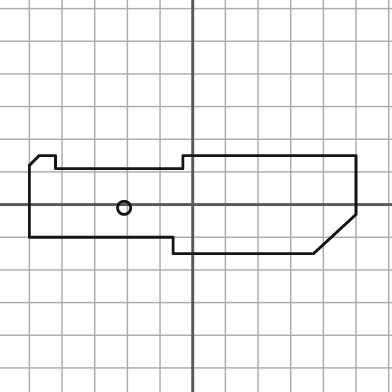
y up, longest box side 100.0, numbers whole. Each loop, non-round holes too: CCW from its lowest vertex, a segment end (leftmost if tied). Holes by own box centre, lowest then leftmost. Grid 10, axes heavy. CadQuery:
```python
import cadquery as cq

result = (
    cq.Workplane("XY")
    .moveTo(-6.0, -15.0)
    .lineTo(37.0, -15.0)
    .lineTo(50.0, -3.0)
    .lineTo(50.0, 15.0)
    .lineTo(-3.0, 15.0)
    .lineTo(-3.0, 11.0)
    .lineTo(-42.0, 11.0)
    .lineTo(-42.0, 15.0)
    .lineTo(-47.0, 15.0)
    .lineTo(-50.0, 12.0)
    .lineTo(-50.0, -10.0)
    .lineTo(-6.0, -10.0)
    .close()
    .moveTo(-21.0, -1.0)
    .circle(2.0)
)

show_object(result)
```